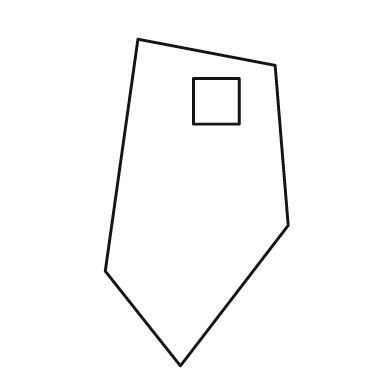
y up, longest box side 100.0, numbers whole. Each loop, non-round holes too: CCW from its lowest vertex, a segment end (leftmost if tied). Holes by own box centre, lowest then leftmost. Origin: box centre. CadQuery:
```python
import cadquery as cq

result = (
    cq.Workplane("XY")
    .moveTo(-5.0, -50.0)
    .lineTo(28.0, -7.0)
    .lineTo(24.0, 42.0)
    .lineTo(-18.0, 50.0)
    .lineTo(-28.0, -21.0)
    .close()
    .moveTo(-1.0, 24.0)
    .lineTo(13.0, 24.0)
    .lineTo(13.0, 38.0)
    .lineTo(-1.0, 38.0)
    .close()
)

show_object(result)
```